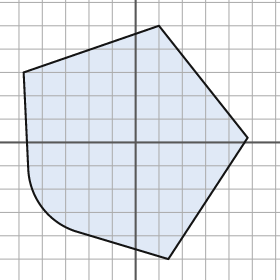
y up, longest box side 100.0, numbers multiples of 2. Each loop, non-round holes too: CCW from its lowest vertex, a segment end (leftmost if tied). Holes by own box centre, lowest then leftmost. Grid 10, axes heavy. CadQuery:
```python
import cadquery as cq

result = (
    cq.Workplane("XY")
    .moveTo(14.0, -50.0)
    .lineTo(48.0, 2.0)
    .lineTo(10.0, 50.0)
    .lineTo(-48.0, 30.0)
    .lineTo(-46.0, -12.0)
    .threePointArc((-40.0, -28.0), (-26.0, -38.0))
    .close()
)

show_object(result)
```